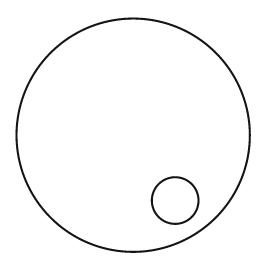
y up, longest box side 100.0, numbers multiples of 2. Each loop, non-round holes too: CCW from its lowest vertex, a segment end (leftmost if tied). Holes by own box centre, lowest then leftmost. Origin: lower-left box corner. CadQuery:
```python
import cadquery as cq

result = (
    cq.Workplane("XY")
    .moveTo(50.0, 50.0)
    .circle(50.0)
    .moveTo(68.0, 22.0)
    .circle(10.0)
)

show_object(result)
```